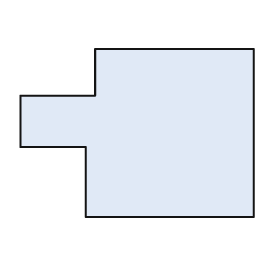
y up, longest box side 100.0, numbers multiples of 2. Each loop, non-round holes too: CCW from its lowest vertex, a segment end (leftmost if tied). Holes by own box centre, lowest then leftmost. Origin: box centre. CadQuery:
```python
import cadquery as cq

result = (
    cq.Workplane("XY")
    .moveTo(-22.0, -36.0)
    .lineTo(50.0, -36.0)
    .lineTo(50.0, 36.0)
    .lineTo(-18.0, 36.0)
    .lineTo(-18.0, 16.0)
    .lineTo(-50.0, 16.0)
    .lineTo(-50.0, -6.0)
    .lineTo(-22.0, -6.0)
    .close()
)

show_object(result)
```